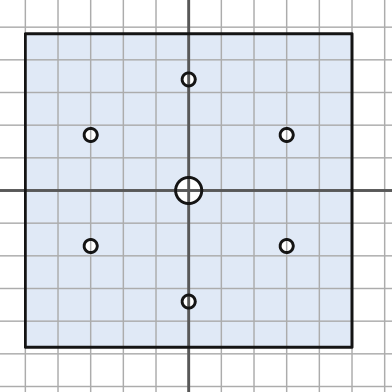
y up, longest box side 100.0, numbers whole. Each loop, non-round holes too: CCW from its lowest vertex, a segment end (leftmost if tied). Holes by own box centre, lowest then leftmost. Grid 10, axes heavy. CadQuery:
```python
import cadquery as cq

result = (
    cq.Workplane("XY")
    .moveTo(-50.0, -48.0)
    .lineTo(50.0, -48.0)
    .lineTo(50.0, 48.0)
    .lineTo(-50.0, 48.0)
    .close()
    .moveTo(0.0, -34.0)
    .circle(2.0)
    .moveTo(-30.0, -17.0)
    .circle(2.0)
    .moveTo(30.0, -17.0)
    .circle(2.0)
    .moveTo(0.0, 0.0)
    .circle(4.0)
    .moveTo(-30.0, 17.0)
    .circle(2.0)
    .moveTo(30.0, 17.0)
    .circle(2.0)
    .moveTo(0.0, 34.0)
    .circle(2.0)
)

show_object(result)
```